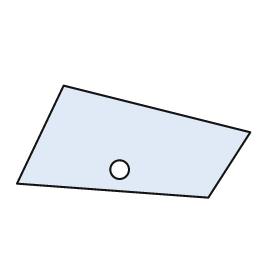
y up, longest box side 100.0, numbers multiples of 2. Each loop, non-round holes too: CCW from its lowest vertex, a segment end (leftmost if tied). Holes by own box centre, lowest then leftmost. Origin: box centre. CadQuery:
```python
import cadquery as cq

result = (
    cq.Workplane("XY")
    .moveTo(32.0, -24.0)
    .lineTo(50.0, 4.0)
    .lineTo(-30.0, 24.0)
    .lineTo(-50.0, -18.0)
    .close()
    .moveTo(-6.0, -12.0)
    .circle(4.0)
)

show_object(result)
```